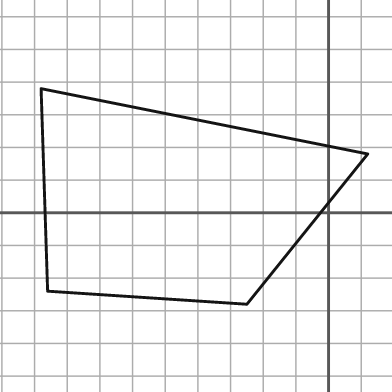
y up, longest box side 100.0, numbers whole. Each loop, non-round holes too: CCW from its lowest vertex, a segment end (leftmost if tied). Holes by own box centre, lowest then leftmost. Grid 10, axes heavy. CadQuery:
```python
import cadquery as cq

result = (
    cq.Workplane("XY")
    .moveTo(-25.0, -28.0)
    .lineTo(12.0, 18.0)
    .lineTo(-88.0, 38.0)
    .lineTo(-86.0, -24.0)
    .close()
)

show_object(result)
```